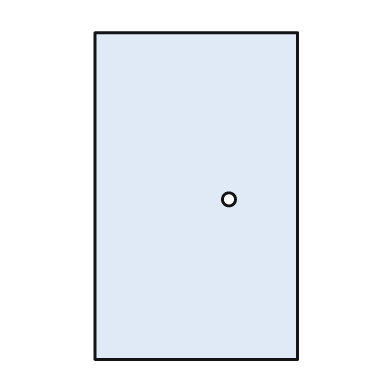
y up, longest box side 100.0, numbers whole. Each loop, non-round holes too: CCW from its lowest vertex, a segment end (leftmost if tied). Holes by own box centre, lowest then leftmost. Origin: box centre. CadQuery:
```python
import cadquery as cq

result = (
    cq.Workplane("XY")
    .moveTo(-31.0, -50.0)
    .lineTo(31.0, -50.0)
    .lineTo(31.0, 50.0)
    .lineTo(-31.0, 50.0)
    .close()
    .moveTo(10.0, -1.0)
    .circle(2.0)
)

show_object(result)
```